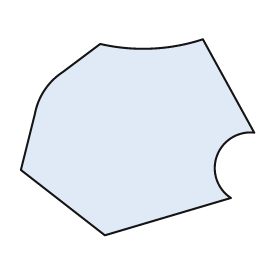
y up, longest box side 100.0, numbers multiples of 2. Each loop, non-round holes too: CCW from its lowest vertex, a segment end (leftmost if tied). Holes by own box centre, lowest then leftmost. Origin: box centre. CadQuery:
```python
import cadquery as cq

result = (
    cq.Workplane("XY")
    .moveTo(-14.0, -42.0)
    .lineTo(40.0, -26.0)
    .threePointArc((34.0, -8.0), (50.0, 2.0))
    .lineTo(28.0, 42.0)
    .threePointArc((6.0, 38.0), (-16.0, 40.0))
    .lineTo(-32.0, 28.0)
    .threePointArc((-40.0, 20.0), (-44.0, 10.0))
    .lineTo(-50.0, -14.0)
    .close()
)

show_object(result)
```